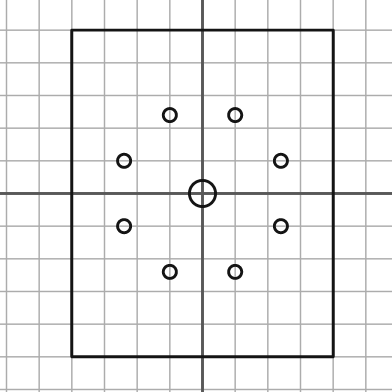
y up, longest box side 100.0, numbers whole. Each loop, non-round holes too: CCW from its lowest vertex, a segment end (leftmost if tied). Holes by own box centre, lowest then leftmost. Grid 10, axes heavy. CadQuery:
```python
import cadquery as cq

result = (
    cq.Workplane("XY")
    .moveTo(-40.0, -50.0)
    .lineTo(40.0, -50.0)
    .lineTo(40.0, 50.0)
    .lineTo(-40.0, 50.0)
    .close()
    .moveTo(-10.0, -24.0)
    .circle(2.0)
    .moveTo(10.0, -24.0)
    .circle(2.0)
    .moveTo(-24.0, -10.0)
    .circle(2.0)
    .moveTo(24.0, -10.0)
    .circle(2.0)
    .moveTo(0.0, 0.0)
    .circle(4.0)
    .moveTo(-24.0, 10.0)
    .circle(2.0)
    .moveTo(24.0, 10.0)
    .circle(2.0)
    .moveTo(-10.0, 24.0)
    .circle(2.0)
    .moveTo(10.0, 24.0)
    .circle(2.0)
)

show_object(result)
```